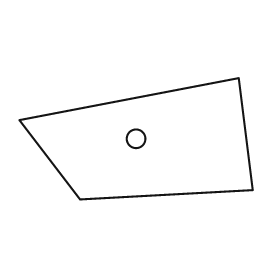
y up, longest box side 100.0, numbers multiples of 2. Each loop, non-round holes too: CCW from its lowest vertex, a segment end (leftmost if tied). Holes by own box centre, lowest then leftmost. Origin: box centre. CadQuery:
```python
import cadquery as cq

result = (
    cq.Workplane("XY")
    .moveTo(-24.0, -26.0)
    .lineTo(50.0, -22.0)
    .lineTo(44.0, 26.0)
    .lineTo(-50.0, 8.0)
    .close()
    .moveTo(0.0, 0.0)
    .circle(4.0)
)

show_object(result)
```